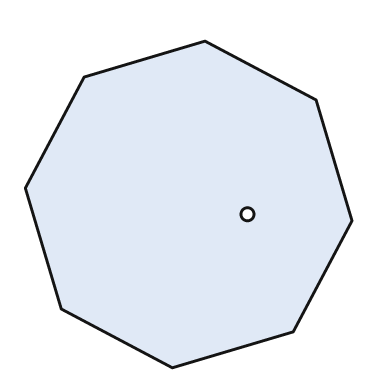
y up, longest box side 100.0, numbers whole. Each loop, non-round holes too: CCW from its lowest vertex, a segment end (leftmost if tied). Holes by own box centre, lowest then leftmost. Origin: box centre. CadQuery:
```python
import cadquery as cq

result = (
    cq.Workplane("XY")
    .moveTo(-5.0, -50.0)
    .lineTo(32.0, -39.0)
    .lineTo(50.0, -5.0)
    .lineTo(39.0, 32.0)
    .lineTo(5.0, 50.0)
    .lineTo(-32.0, 39.0)
    .lineTo(-50.0, 5.0)
    .lineTo(-39.0, -32.0)
    .close()
    .moveTo(18.0, -3.0)
    .circle(2.0)
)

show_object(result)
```